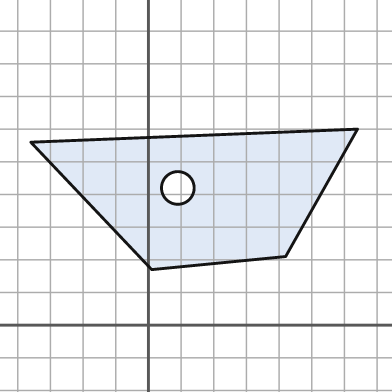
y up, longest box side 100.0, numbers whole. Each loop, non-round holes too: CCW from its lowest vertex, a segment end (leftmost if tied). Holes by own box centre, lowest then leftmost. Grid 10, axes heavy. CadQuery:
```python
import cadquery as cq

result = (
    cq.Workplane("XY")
    .moveTo(1.0, 17.0)
    .lineTo(42.0, 21.0)
    .lineTo(64.0, 60.0)
    .lineTo(-36.0, 56.0)
    .close()
    .moveTo(9.0, 42.0)
    .circle(5.0)
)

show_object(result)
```